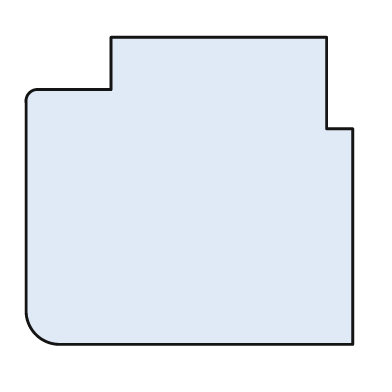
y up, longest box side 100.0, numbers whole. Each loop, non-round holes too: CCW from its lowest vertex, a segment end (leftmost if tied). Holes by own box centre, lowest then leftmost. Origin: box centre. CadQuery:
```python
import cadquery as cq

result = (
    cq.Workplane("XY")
    .moveTo(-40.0, -47.0)
    .lineTo(50.0, -47.0)
    .lineTo(50.0, 19.0)
    .lineTo(42.0, 19.0)
    .lineTo(42.0, 47.0)
    .lineTo(-24.0, 47.0)
    .lineTo(-24.0, 31.0)
    .lineTo(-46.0, 31.0)
    .threePointArc((-49.0, 30.0), (-50.0, 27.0))
    .lineTo(-50.0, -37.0)
    .threePointArc((-47.0, -44.0), (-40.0, -47.0))
    .close()
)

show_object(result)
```